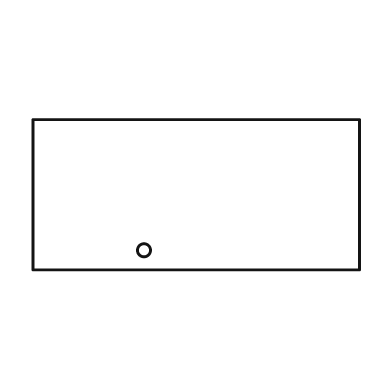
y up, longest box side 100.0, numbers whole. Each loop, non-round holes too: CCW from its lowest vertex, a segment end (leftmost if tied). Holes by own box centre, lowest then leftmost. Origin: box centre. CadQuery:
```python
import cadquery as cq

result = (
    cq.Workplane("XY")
    .moveTo(-50.0, -23.0)
    .lineTo(50.0, -23.0)
    .lineTo(50.0, 23.0)
    .lineTo(-50.0, 23.0)
    .close()
    .moveTo(-16.0, -17.0)
    .circle(2.0)
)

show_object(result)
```